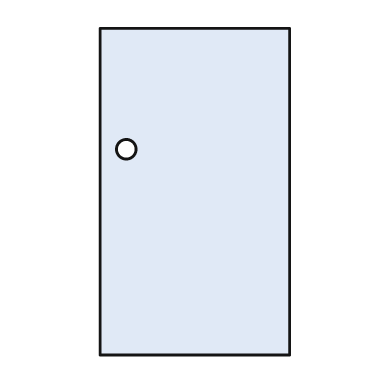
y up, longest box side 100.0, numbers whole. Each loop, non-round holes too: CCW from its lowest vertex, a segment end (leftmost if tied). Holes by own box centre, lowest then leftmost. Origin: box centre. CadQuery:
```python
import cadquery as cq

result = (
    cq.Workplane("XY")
    .moveTo(-29.0, -50.0)
    .lineTo(29.0, -50.0)
    .lineTo(29.0, 50.0)
    .lineTo(-29.0, 50.0)
    .close()
    .moveTo(-21.0, 13.0)
    .circle(3.0)
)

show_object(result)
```